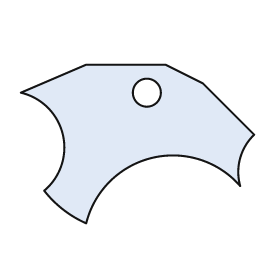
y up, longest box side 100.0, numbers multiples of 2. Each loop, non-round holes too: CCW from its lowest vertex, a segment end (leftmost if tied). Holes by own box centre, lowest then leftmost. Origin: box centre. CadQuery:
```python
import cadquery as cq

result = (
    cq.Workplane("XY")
    .moveTo(-22.0, -34.0)
    .threePointArc((6.0, -6.0), (44.0, -18.0))
    .threePointArc((44.0, -6.0), (50.0, 4.0))
    .lineTo(28.0, 26.0)
    .lineTo(12.0, 34.0)
    .lineTo(-22.0, 34.0)
    .lineTo(-50.0, 22.0)
    .threePointArc((-32.0, 4.0), (-40.0, -20.0))
    .threePointArc((-32.0, -28.0), (-22.0, -34.0))
    .close()
    .moveTo(4.0, 22.0)
    .circle(6.0)
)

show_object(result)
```